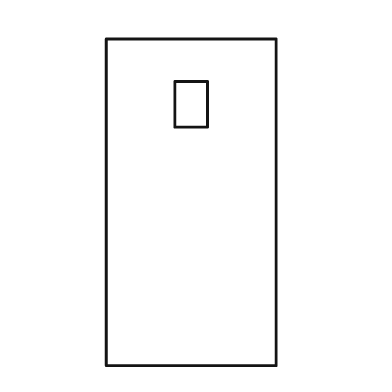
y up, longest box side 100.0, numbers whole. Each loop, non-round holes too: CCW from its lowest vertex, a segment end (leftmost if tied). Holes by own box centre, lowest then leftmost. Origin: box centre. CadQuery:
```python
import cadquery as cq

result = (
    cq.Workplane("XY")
    .moveTo(-26.0, -50.0)
    .lineTo(26.0, -50.0)
    .lineTo(26.0, 50.0)
    .lineTo(-26.0, 50.0)
    .close()
    .moveTo(-5.0, 23.0)
    .lineTo(5.0, 23.0)
    .lineTo(5.0, 37.0)
    .lineTo(-5.0, 37.0)
    .close()
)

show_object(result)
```